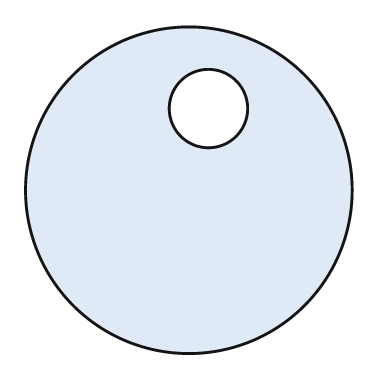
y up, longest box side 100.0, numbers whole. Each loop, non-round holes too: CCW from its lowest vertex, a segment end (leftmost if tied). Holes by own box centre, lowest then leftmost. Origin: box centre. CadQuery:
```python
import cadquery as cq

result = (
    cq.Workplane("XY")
    .moveTo(0.0, 0.0)
    .circle(50.0)
    .moveTo(6.0, 25.0)
    .circle(12.0)
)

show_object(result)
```